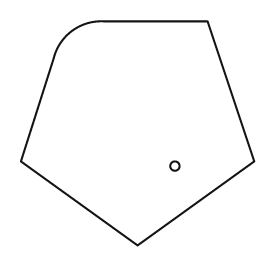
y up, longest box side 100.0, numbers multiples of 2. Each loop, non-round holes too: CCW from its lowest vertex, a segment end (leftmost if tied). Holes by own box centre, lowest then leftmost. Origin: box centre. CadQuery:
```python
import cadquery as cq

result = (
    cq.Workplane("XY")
    .moveTo(0.0, -48.0)
    .lineTo(50.0, -12.0)
    .lineTo(30.0, 48.0)
    .lineTo(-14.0, 48.0)
    .threePointArc((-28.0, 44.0), (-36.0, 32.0))
    .lineTo(-50.0, -12.0)
    .close()
    .moveTo(16.0, -14.0)
    .circle(2.0)
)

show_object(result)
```